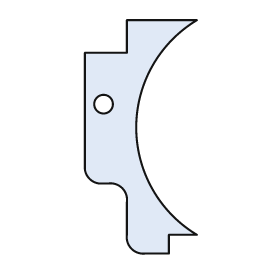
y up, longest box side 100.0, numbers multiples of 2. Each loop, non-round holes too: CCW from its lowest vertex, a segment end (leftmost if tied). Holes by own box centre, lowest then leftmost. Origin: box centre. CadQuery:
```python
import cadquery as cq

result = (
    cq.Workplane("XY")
    .moveTo(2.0, -50.0)
    .lineTo(12.0, -50.0)
    .lineTo(12.0, -42.0)
    .lineTo(24.0, -42.0)
    .threePointArc((-2.0, 4.0), (24.0, 50.0))
    .lineTo(-6.0, 50.0)
    .lineTo(-6.0, 36.0)
    .lineTo(-24.0, 36.0)
    .lineTo(-24.0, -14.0)
    .threePointArc((-22.0, -18.0), (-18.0, -20.0))
    .lineTo(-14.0, -20.0)
    .threePointArc((-8.0, -22.0), (-6.0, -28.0))
    .lineTo(-6.0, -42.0)
    .threePointArc((-4.0, -48.0), (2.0, -50.0))
    .close()
    .moveTo(-16.0, 14.0)
    .circle(4.0)
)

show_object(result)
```